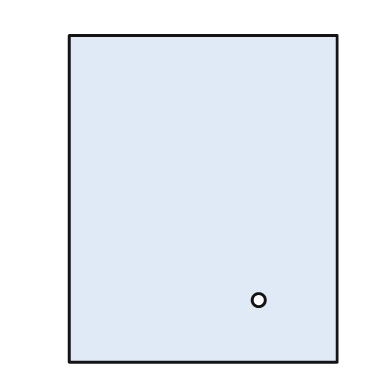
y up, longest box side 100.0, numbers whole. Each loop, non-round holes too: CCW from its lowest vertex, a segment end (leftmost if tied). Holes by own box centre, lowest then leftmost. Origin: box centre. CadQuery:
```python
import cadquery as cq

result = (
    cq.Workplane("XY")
    .moveTo(-41.0, -50.0)
    .lineTo(41.0, -50.0)
    .lineTo(41.0, 50.0)
    .lineTo(-41.0, 50.0)
    .close()
    .moveTo(17.0, -31.0)
    .circle(2.0)
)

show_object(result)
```